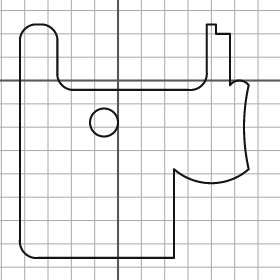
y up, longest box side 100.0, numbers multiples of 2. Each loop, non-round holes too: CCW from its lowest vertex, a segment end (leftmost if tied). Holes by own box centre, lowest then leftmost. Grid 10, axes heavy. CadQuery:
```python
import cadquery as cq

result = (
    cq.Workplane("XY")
    .moveTo(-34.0, -76.0)
    .lineTo(24.0, -76.0)
    .lineTo(24.0, -38.0)
    .threePointArc((40.0, -44.0), (56.0, -38.0))
    .threePointArc((54.0, -20.0), (56.0, -2.0))
    .threePointArc((52.0, 0.0), (48.0, -2.0))
    .lineTo(48.0, 20.0)
    .lineTo(42.0, 20.0)
    .lineTo(42.0, 24.0)
    .lineTo(38.0, 24.0)
    .lineTo(38.0, 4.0)
    .threePointArc((36.0, -2.0), (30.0, -4.0))
    .lineTo(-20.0, -4.0)
    .threePointArc((-24.0, -2.0), (-26.0, 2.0))
    .lineTo(-26.0, 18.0)
    .threePointArc((-28.0, 22.0), (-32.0, 24.0))
    .lineTo(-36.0, 24.0)
    .threePointArc((-40.0, 22.0), (-42.0, 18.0))
    .lineTo(-42.0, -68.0)
    .threePointArc((-40.0, -74.0), (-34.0, -76.0))
    .close()
    .moveTo(-6.0, -18.0)
    .circle(6.0)
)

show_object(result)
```